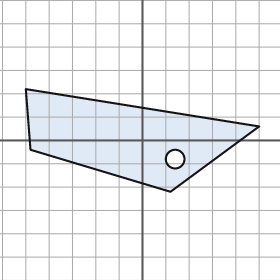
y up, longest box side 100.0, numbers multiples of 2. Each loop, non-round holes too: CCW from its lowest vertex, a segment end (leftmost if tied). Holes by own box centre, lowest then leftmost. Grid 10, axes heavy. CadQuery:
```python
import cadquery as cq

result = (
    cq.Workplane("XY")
    .moveTo(12.0, -22.0)
    .lineTo(50.0, 6.0)
    .lineTo(-50.0, 22.0)
    .lineTo(-48.0, -4.0)
    .close()
    .moveTo(14.0, -8.0)
    .circle(4.0)
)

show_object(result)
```